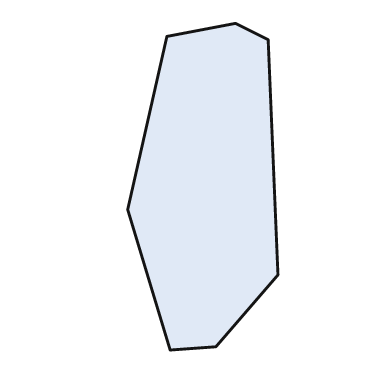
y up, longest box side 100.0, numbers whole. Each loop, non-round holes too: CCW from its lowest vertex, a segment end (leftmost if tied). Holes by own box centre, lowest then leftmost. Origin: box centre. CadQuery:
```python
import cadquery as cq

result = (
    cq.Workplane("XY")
    .moveTo(-10.0, -50.0)
    .lineTo(4.0, -49.0)
    .lineTo(23.0, -27.0)
    .lineTo(20.0, 45.0)
    .lineTo(10.0, 50.0)
    .lineTo(-11.0, 46.0)
    .lineTo(-23.0, -7.0)
    .close()
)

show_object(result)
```